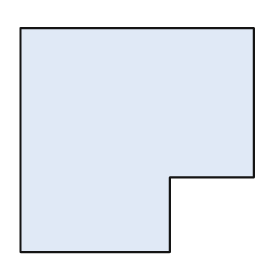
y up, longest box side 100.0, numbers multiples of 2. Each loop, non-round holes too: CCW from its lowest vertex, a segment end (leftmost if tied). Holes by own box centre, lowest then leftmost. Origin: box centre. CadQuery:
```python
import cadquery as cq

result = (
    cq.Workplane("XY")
    .moveTo(-50.0, -48.0)
    .lineTo(14.0, -48.0)
    .lineTo(14.0, -16.0)
    .lineTo(50.0, -16.0)
    .lineTo(50.0, 48.0)
    .lineTo(-50.0, 48.0)
    .close()
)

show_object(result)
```